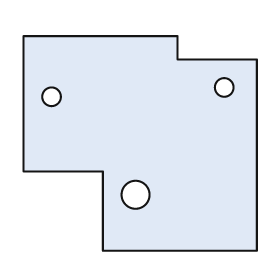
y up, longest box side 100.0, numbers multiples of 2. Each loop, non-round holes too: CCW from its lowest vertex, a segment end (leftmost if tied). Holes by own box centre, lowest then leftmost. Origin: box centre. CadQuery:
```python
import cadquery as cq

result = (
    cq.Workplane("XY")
    .moveTo(-16.0, -46.0)
    .lineTo(50.0, -46.0)
    .lineTo(50.0, 36.0)
    .lineTo(16.0, 36.0)
    .lineTo(16.0, 46.0)
    .lineTo(-50.0, 46.0)
    .lineTo(-50.0, -12.0)
    .lineTo(-16.0, -12.0)
    .close()
    .moveTo(-2.0, -22.0)
    .circle(6.0)
    .moveTo(-38.0, 20.0)
    .circle(4.0)
    .moveTo(36.0, 24.0)
    .circle(4.0)
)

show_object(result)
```